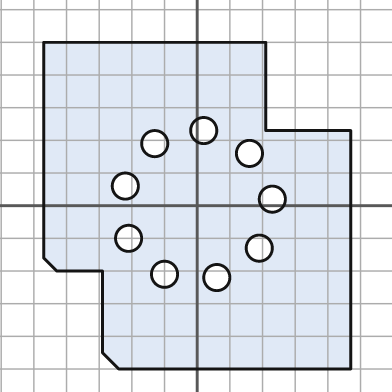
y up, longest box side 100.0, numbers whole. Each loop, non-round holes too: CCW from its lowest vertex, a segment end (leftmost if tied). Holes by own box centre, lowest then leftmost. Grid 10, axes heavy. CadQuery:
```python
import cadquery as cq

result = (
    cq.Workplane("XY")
    .moveTo(-24.0, -50.0)
    .lineTo(47.0, -50.0)
    .lineTo(47.0, 23.0)
    .lineTo(21.0, 23.0)
    .lineTo(21.0, 50.0)
    .lineTo(-47.0, 50.0)
    .lineTo(-47.0, -16.0)
    .lineTo(-43.0, -20.0)
    .lineTo(-29.0, -20.0)
    .lineTo(-29.0, -45.0)
    .close()
    .moveTo(6.0, -22.0)
    .circle(4.0)
    .moveTo(-10.0, -21.0)
    .circle(4.0)
    .moveTo(19.0, -13.0)
    .circle(4.0)
    .moveTo(-21.0, -10.0)
    .circle(4.0)
    .moveTo(23.0, 2.0)
    .circle(4.0)
    .moveTo(-22.0, 6.0)
    .circle(4.0)
    .moveTo(16.0, 16.0)
    .circle(4.0)
    .moveTo(-13.0, 19.0)
    .circle(4.0)
    .moveTo(2.0, 23.0)
    .circle(4.0)
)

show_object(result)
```